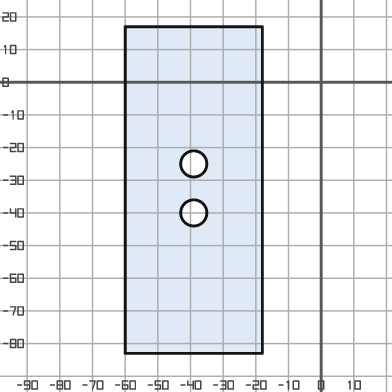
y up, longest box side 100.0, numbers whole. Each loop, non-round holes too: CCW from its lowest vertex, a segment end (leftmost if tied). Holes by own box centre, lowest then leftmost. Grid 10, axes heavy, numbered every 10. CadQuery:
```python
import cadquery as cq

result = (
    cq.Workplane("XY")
    .moveTo(-60.0, -83.0)
    .lineTo(-18.0, -83.0)
    .lineTo(-18.0, 17.0)
    .lineTo(-60.0, 17.0)
    .close()
    .moveTo(-39.0, -40.0)
    .circle(4.0)
    .moveTo(-39.0, -25.0)
    .circle(4.0)
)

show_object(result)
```